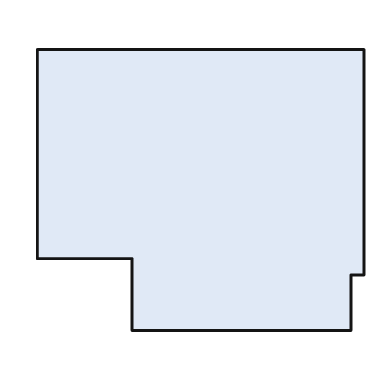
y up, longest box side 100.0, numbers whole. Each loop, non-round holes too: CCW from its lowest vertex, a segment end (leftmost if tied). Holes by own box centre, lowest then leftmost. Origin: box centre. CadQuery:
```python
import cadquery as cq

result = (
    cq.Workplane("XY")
    .moveTo(-21.0, -43.0)
    .lineTo(46.0, -43.0)
    .lineTo(46.0, -26.0)
    .lineTo(50.0, -26.0)
    .lineTo(50.0, 43.0)
    .lineTo(-50.0, 43.0)
    .lineTo(-50.0, -21.0)
    .lineTo(-21.0, -21.0)
    .close()
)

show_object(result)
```